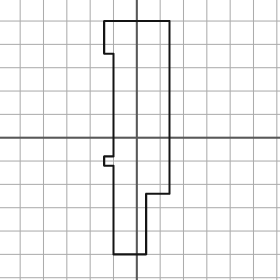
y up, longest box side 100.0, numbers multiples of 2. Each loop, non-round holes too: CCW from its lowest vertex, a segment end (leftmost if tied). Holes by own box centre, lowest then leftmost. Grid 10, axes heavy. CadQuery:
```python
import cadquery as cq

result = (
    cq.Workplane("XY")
    .moveTo(-10.0, -50.0)
    .lineTo(4.0, -50.0)
    .lineTo(4.0, -24.0)
    .lineTo(14.0, -24.0)
    .lineTo(14.0, 50.0)
    .lineTo(-14.0, 50.0)
    .lineTo(-14.0, 36.0)
    .lineTo(-10.0, 36.0)
    .lineTo(-10.0, -8.0)
    .lineTo(-14.0, -8.0)
    .lineTo(-14.0, -12.0)
    .lineTo(-10.0, -12.0)
    .close()
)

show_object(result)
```